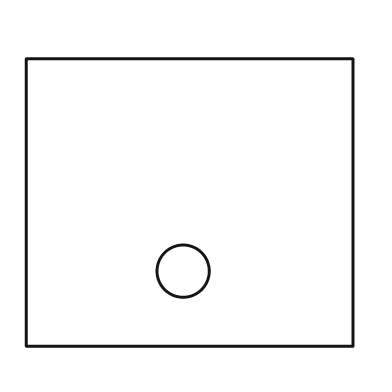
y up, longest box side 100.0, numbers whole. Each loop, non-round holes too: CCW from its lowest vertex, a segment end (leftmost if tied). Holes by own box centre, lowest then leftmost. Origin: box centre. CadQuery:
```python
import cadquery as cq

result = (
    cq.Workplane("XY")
    .moveTo(-50.0, -44.0)
    .lineTo(50.0, -44.0)
    .lineTo(50.0, 44.0)
    .lineTo(-50.0, 44.0)
    .close()
    .moveTo(-2.0, -21.0)
    .circle(8.0)
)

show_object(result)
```